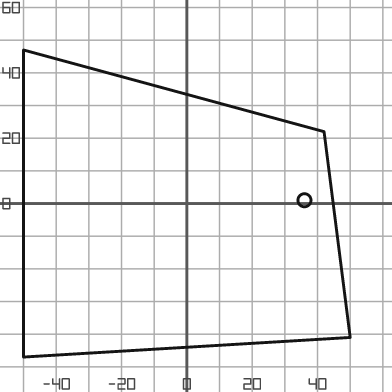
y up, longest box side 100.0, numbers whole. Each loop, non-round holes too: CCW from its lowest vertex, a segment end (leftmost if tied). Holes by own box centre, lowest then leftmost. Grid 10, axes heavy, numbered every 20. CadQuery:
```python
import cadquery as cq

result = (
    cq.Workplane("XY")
    .moveTo(-50.0, -47.0)
    .lineTo(50.0, -41.0)
    .lineTo(42.0, 22.0)
    .lineTo(-50.0, 47.0)
    .close()
    .moveTo(36.0, 1.0)
    .circle(2.0)
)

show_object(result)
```